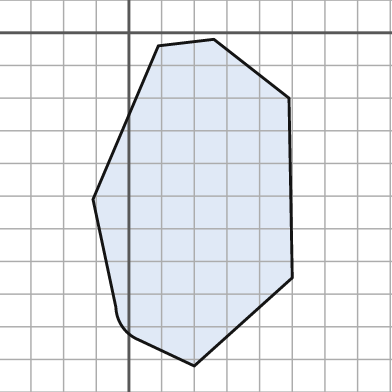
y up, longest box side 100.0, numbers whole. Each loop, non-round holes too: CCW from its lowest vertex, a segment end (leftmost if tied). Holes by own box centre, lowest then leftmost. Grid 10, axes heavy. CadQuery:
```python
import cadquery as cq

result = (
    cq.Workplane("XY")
    .moveTo(20.0, -102.0)
    .lineTo(50.0, -75.0)
    .lineTo(49.0, -20.0)
    .lineTo(26.0, -2.0)
    .lineTo(9.0, -4.0)
    .lineTo(-11.0, -51.0)
    .lineTo(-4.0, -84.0)
    .threePointArc((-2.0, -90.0), (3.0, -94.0))
    .close()
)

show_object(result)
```